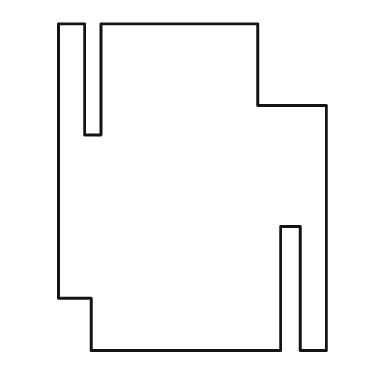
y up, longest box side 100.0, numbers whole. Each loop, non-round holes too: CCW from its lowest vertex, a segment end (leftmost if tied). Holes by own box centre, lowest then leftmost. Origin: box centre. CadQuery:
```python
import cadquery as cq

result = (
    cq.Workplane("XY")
    .moveTo(-31.0, -50.0)
    .lineTo(27.0, -50.0)
    .lineTo(27.0, -12.0)
    .lineTo(33.0, -12.0)
    .lineTo(33.0, -50.0)
    .lineTo(41.0, -50.0)
    .lineTo(41.0, 25.0)
    .lineTo(20.0, 25.0)
    .lineTo(20.0, 50.0)
    .lineTo(-28.0, 50.0)
    .lineTo(-28.0, 16.0)
    .lineTo(-33.0, 16.0)
    .lineTo(-33.0, 50.0)
    .lineTo(-41.0, 50.0)
    .lineTo(-41.0, -34.0)
    .lineTo(-31.0, -34.0)
    .close()
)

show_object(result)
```